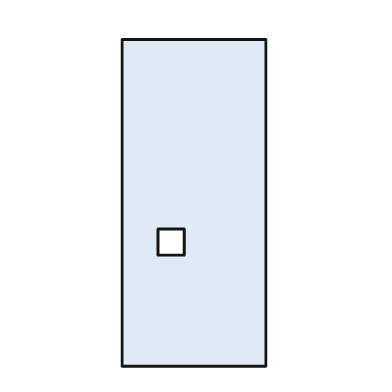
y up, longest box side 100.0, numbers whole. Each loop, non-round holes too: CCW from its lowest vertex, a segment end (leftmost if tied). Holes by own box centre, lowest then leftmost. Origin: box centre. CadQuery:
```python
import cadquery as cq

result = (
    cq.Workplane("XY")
    .moveTo(-22.0, -50.0)
    .lineTo(22.0, -50.0)
    .lineTo(22.0, 50.0)
    .lineTo(-22.0, 50.0)
    .close()
    .moveTo(-11.0, -16.0)
    .lineTo(-3.0, -16.0)
    .lineTo(-3.0, -8.0)
    .lineTo(-11.0, -8.0)
    .close()
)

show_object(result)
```